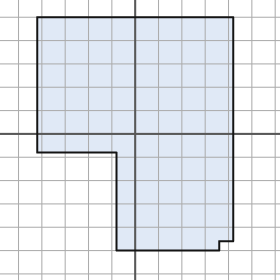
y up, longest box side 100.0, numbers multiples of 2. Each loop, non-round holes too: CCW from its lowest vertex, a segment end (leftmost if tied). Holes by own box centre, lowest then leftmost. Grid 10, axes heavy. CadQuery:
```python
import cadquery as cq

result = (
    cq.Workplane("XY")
    .moveTo(-8.0, -50.0)
    .lineTo(36.0, -50.0)
    .lineTo(36.0, -46.0)
    .lineTo(42.0, -46.0)
    .lineTo(42.0, 50.0)
    .lineTo(-42.0, 50.0)
    .lineTo(-42.0, -8.0)
    .lineTo(-8.0, -8.0)
    .close()
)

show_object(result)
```